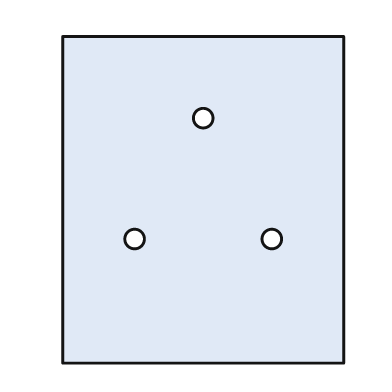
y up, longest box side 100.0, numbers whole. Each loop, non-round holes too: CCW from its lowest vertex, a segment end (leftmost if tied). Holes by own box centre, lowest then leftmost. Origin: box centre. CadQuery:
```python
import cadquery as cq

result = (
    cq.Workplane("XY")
    .moveTo(-43.0, -50.0)
    .lineTo(43.0, -50.0)
    .lineTo(43.0, 50.0)
    .lineTo(-43.0, 50.0)
    .close()
    .moveTo(-21.0, -12.0)
    .circle(3.0)
    .moveTo(21.0, -12.0)
    .circle(3.0)
    .moveTo(0.0, 25.0)
    .circle(3.0)
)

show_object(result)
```